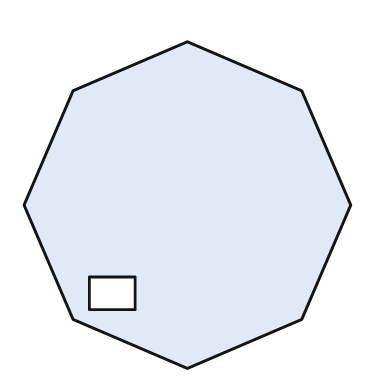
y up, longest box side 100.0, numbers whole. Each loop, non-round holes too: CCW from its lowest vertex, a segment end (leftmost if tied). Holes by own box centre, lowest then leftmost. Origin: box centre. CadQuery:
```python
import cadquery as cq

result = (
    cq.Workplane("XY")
    .moveTo(0.0, -50.0)
    .lineTo(35.0, -35.0)
    .lineTo(50.0, 0.0)
    .lineTo(35.0, 35.0)
    .lineTo(0.0, 50.0)
    .lineTo(-35.0, 35.0)
    .lineTo(-50.0, 0.0)
    .lineTo(-35.0, -35.0)
    .close()
    .moveTo(-30.0, -32.0)
    .lineTo(-16.0, -32.0)
    .lineTo(-16.0, -22.0)
    .lineTo(-30.0, -22.0)
    .close()
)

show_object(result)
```